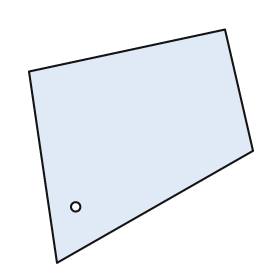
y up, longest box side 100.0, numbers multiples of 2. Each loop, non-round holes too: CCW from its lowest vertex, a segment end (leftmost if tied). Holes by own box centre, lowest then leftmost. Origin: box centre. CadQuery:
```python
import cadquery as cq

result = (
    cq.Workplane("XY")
    .moveTo(-36.0, -50.0)
    .lineTo(48.0, -2.0)
    .lineTo(36.0, 50.0)
    .lineTo(-48.0, 32.0)
    .close()
    .moveTo(-28.0, -26.0)
    .circle(2.0)
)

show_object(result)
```